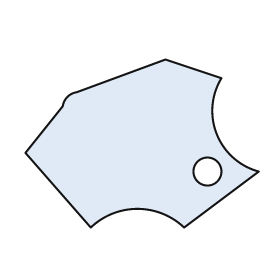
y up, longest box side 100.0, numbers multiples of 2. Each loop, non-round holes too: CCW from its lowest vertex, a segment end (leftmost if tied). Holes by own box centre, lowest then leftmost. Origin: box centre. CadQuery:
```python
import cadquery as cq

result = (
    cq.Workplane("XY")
    .moveTo(-22.0, -36.0)
    .threePointArc((-2.0, -28.0), (18.0, -36.0))
    .lineTo(50.0, -12.0)
    .threePointArc((32.0, 4.0), (34.0, 28.0))
    .lineTo(10.0, 36.0)
    .lineTo(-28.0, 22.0)
    .threePointArc((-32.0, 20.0), (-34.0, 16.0))
    .lineTo(-50.0, -4.0)
    .close()
    .moveTo(28.0, -12.0)
    .circle(6.0)
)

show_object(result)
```